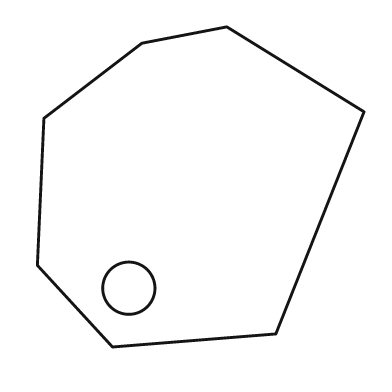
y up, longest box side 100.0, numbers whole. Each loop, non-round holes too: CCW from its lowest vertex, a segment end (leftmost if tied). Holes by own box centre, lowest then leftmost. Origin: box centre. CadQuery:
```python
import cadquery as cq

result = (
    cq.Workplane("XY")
    .moveTo(-27.0, -49.0)
    .lineTo(23.0, -45.0)
    .lineTo(50.0, 23.0)
    .lineTo(8.0, 49.0)
    .lineTo(-18.0, 44.0)
    .lineTo(-48.0, 21.0)
    .lineTo(-50.0, -24.0)
    .close()
    .moveTo(-22.0, -31.0)
    .circle(8.0)
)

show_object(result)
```